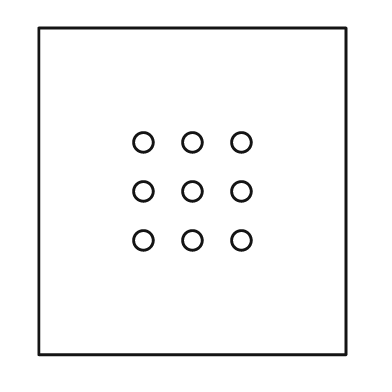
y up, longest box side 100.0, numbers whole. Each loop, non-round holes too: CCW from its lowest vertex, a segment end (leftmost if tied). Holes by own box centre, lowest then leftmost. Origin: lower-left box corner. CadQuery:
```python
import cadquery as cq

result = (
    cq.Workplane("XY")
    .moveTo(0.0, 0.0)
    .lineTo(94.0, 0.0)
    .lineTo(94.0, 100.0)
    .lineTo(0.0, 100.0)
    .close()
    .moveTo(32.0, 35.0)
    .circle(3.0)
    .moveTo(47.0, 35.0)
    .circle(3.0)
    .moveTo(62.0, 35.0)
    .circle(3.0)
    .moveTo(32.0, 50.0)
    .circle(3.0)
    .moveTo(47.0, 50.0)
    .circle(3.0)
    .moveTo(62.0, 50.0)
    .circle(3.0)
    .moveTo(32.0, 65.0)
    .circle(3.0)
    .moveTo(47.0, 65.0)
    .circle(3.0)
    .moveTo(62.0, 65.0)
    .circle(3.0)
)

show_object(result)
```